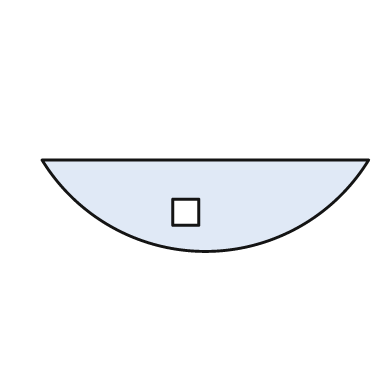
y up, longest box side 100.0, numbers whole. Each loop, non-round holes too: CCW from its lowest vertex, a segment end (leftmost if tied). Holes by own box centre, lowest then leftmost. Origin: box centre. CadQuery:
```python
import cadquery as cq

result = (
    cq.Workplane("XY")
    .moveTo(-50.0, 14.0)
    .threePointArc((0.0, -14.0), (50.0, 14.0))
    .close()
    .moveTo(-10.0, -6.0)
    .lineTo(-2.0, -6.0)
    .lineTo(-2.0, 2.0)
    .lineTo(-10.0, 2.0)
    .close()
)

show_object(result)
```